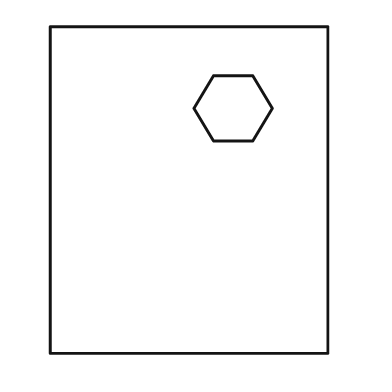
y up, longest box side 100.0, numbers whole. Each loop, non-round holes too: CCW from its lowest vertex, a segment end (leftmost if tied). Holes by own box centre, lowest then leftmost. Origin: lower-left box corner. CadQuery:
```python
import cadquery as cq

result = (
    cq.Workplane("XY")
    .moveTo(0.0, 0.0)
    .lineTo(85.0, 0.0)
    .lineTo(85.0, 100.0)
    .lineTo(0.0, 100.0)
    .close()
    .moveTo(50.0, 65.0)
    .lineTo(62.0, 65.0)
    .lineTo(68.0, 75.0)
    .lineTo(62.0, 85.0)
    .lineTo(50.0, 85.0)
    .lineTo(44.0, 75.0)
    .close()
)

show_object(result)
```